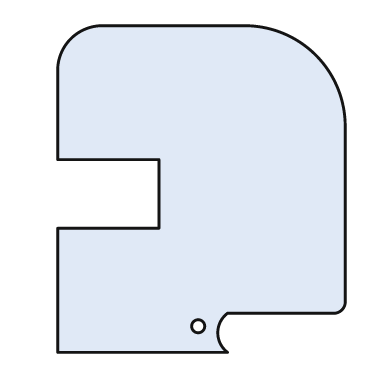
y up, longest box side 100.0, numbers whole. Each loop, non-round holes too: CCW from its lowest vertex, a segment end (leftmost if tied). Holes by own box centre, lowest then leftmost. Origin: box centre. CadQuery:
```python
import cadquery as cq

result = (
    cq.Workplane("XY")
    .moveTo(-44.0, -50.0)
    .lineTo(8.0, -50.0)
    .threePointArc((5.0, -44.0), (8.0, -38.0))
    .lineTo(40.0, -38.0)
    .threePointArc((43.0, -37.0), (44.0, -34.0))
    .lineTo(44.0, 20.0)
    .threePointArc((35.0, 41.0), (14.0, 50.0))
    .lineTo(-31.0, 50.0)
    .threePointArc((-40.0, 46.0), (-44.0, 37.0))
    .lineTo(-44.0, 9.0)
    .lineTo(-13.0, 9.0)
    .lineTo(-13.0, -12.0)
    .lineTo(-44.0, -12.0)
    .close()
    .moveTo(-1.0, -42.0)
    .circle(2.0)
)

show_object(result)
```